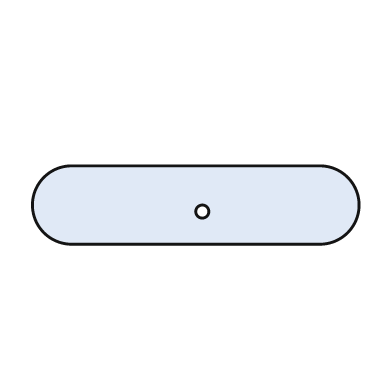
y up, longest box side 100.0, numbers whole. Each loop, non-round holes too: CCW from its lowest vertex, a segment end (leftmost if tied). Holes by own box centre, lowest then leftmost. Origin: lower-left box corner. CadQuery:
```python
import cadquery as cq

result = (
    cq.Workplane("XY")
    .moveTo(12.0, 0.0)
    .lineTo(88.0, 0.0)
    .threePointArc((100.0, 12.0), (88.0, 24.0))
    .lineTo(12.0, 24.0)
    .threePointArc((0.0, 12.0), (12.0, 0.0))
    .close()
    .moveTo(52.0, 10.0)
    .circle(2.0)
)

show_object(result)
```